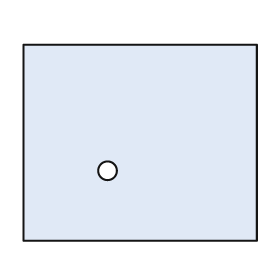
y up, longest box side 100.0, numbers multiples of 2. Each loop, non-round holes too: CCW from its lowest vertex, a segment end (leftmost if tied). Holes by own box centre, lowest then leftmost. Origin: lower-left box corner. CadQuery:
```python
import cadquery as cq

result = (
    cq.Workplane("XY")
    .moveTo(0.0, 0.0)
    .lineTo(100.0, 0.0)
    .lineTo(100.0, 84.0)
    .lineTo(0.0, 84.0)
    .close()
    .moveTo(36.0, 30.0)
    .circle(4.0)
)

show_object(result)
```